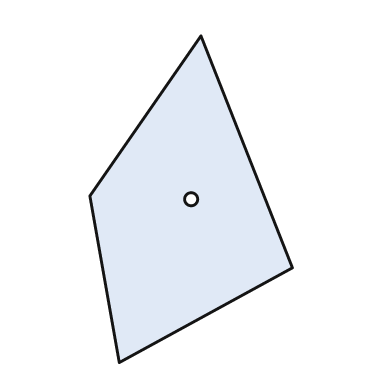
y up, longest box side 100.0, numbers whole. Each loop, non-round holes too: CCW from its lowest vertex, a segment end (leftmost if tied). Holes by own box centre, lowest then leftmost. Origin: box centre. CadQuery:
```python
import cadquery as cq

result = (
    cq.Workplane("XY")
    .moveTo(-22.0, -50.0)
    .lineTo(31.0, -21.0)
    .lineTo(3.0, 50.0)
    .lineTo(-31.0, 1.0)
    .close()
    .moveTo(0.0, 0.0)
    .circle(2.0)
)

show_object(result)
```